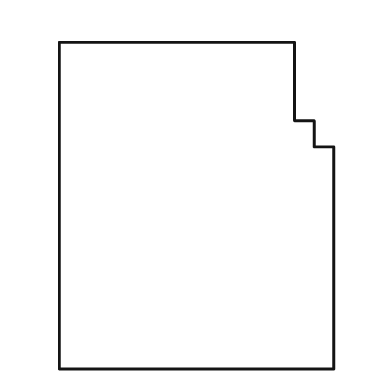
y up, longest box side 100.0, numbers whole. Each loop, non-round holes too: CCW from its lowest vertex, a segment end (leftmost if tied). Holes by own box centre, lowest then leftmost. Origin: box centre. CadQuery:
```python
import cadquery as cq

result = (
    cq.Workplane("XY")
    .moveTo(-42.0, -50.0)
    .lineTo(42.0, -50.0)
    .lineTo(42.0, 18.0)
    .lineTo(36.0, 18.0)
    .lineTo(36.0, 26.0)
    .lineTo(30.0, 26.0)
    .lineTo(30.0, 50.0)
    .lineTo(-42.0, 50.0)
    .close()
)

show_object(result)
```